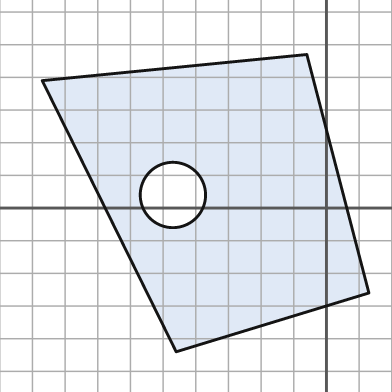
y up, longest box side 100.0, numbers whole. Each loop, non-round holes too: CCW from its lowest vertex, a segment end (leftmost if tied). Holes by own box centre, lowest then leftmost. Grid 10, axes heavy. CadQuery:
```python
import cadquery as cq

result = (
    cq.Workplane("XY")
    .moveTo(-46.0, -44.0)
    .lineTo(13.0, -26.0)
    .lineTo(-6.0, 47.0)
    .lineTo(-87.0, 39.0)
    .close()
    .moveTo(-47.0, 4.0)
    .circle(10.0)
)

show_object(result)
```